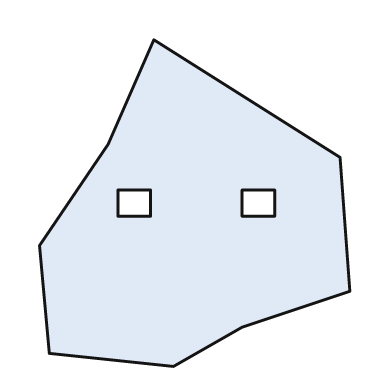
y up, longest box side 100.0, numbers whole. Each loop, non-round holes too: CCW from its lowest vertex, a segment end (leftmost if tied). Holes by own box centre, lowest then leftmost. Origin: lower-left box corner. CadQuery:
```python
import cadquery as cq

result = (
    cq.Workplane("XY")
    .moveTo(41.0, 0.0)
    .lineTo(62.0, 12.0)
    .lineTo(95.0, 23.0)
    .lineTo(92.0, 64.0)
    .lineTo(35.0, 100.0)
    .lineTo(21.0, 68.0)
    .lineTo(0.0, 37.0)
    .lineTo(3.0, 4.0)
    .close()
    .moveTo(24.0, 46.0)
    .lineTo(34.0, 46.0)
    .lineTo(34.0, 54.0)
    .lineTo(24.0, 54.0)
    .close()
    .moveTo(62.0, 46.0)
    .lineTo(72.0, 46.0)
    .lineTo(72.0, 54.0)
    .lineTo(62.0, 54.0)
    .close()
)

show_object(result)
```